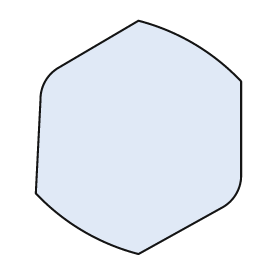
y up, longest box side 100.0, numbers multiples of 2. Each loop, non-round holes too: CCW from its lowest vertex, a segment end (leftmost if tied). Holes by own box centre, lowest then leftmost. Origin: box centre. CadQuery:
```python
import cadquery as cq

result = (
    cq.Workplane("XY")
    .moveTo(0.0, -50.0)
    .lineTo(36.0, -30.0)
    .threePointArc((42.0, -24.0), (44.0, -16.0))
    .lineTo(44.0, 24.0)
    .threePointArc((24.0, 40.0), (0.0, 50.0))
    .lineTo(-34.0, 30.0)
    .threePointArc((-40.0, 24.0), (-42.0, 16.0))
    .lineTo(-44.0, -24.0)
    .threePointArc((-24.0, -40.0), (0.0, -50.0))
    .close()
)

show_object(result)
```